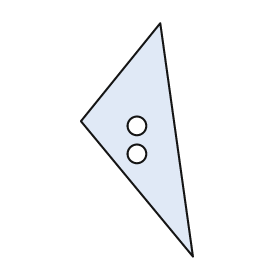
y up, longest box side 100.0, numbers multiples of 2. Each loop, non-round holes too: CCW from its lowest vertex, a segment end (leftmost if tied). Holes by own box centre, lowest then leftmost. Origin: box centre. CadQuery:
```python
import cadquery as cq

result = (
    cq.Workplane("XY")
    .moveTo(24.0, -50.0)
    .lineTo(10.0, 50.0)
    .lineTo(-24.0, 8.0)
    .close()
    .moveTo(0.0, -6.0)
    .circle(4.0)
    .moveTo(0.0, 6.0)
    .circle(4.0)
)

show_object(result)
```